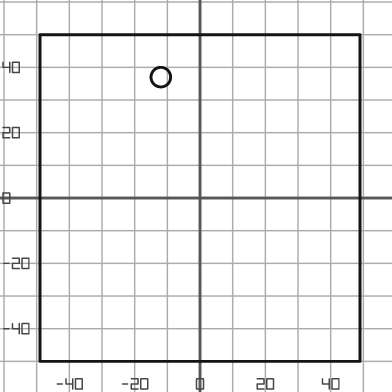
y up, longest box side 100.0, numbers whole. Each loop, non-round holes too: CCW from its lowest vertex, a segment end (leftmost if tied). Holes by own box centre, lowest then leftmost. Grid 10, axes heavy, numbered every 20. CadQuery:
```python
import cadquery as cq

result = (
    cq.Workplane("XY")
    .moveTo(-49.0, -50.0)
    .lineTo(49.0, -50.0)
    .lineTo(49.0, 50.0)
    .lineTo(-49.0, 50.0)
    .close()
    .moveTo(-12.0, 37.0)
    .circle(3.0)
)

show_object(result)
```